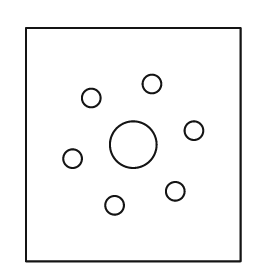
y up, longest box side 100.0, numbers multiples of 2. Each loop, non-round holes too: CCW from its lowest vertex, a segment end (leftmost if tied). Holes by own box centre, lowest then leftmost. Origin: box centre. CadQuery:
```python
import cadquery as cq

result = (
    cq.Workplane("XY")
    .moveTo(-46.0, -50.0)
    .lineTo(46.0, -50.0)
    .lineTo(46.0, 50.0)
    .lineTo(-46.0, 50.0)
    .close()
    .moveTo(-8.0, -26.0)
    .circle(4.0)
    .moveTo(18.0, -20.0)
    .circle(4.0)
    .moveTo(-26.0, -6.0)
    .circle(4.0)
    .moveTo(0.0, 0.0)
    .circle(10.0)
    .moveTo(26.0, 6.0)
    .circle(4.0)
    .moveTo(-18.0, 20.0)
    .circle(4.0)
    .moveTo(8.0, 26.0)
    .circle(4.0)
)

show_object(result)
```